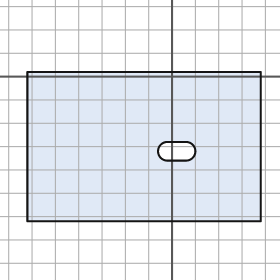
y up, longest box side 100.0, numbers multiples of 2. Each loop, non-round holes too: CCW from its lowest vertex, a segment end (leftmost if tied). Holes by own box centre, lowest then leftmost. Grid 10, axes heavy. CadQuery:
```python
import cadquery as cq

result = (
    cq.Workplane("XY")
    .moveTo(-62.0, -62.0)
    .lineTo(38.0, -62.0)
    .lineTo(38.0, 2.0)
    .lineTo(-62.0, 2.0)
    .close()
    .moveTo(-2.0, -36.0)
    .lineTo(6.0, -36.0)
    .threePointArc((10.0, -32.0), (6.0, -28.0))
    .lineTo(-2.0, -28.0)
    .threePointArc((-6.0, -32.0), (-2.0, -36.0))
    .close()
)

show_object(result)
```